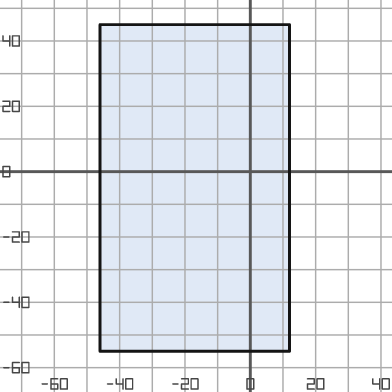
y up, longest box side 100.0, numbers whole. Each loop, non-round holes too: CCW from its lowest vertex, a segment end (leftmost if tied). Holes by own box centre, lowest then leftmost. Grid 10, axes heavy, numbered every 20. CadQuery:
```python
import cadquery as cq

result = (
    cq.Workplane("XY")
    .moveTo(-46.0, -55.0)
    .lineTo(12.0, -55.0)
    .lineTo(12.0, 45.0)
    .lineTo(-46.0, 45.0)
    .close()
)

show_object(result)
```